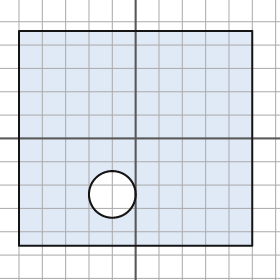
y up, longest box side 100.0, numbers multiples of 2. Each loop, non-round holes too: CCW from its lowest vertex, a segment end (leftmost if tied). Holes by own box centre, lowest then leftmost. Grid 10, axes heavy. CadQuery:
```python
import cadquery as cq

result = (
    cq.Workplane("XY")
    .moveTo(-50.0, -46.0)
    .lineTo(50.0, -46.0)
    .lineTo(50.0, 46.0)
    .lineTo(-50.0, 46.0)
    .close()
    .moveTo(-10.0, -24.0)
    .circle(10.0)
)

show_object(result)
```